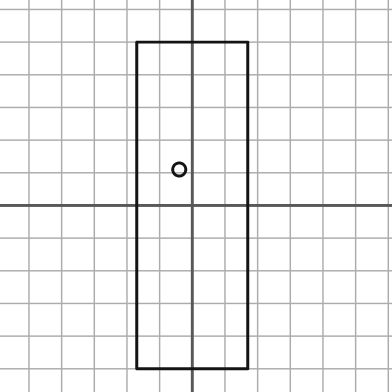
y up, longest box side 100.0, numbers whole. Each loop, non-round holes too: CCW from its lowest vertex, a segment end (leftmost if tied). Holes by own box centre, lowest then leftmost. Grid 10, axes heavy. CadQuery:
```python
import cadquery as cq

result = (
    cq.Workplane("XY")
    .moveTo(-17.0, -50.0)
    .lineTo(17.0, -50.0)
    .lineTo(17.0, 50.0)
    .lineTo(-17.0, 50.0)
    .close()
    .moveTo(-4.0, 11.0)
    .circle(2.0)
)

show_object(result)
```